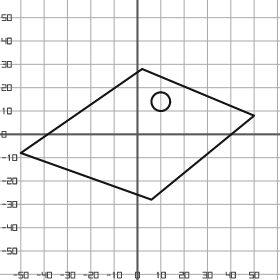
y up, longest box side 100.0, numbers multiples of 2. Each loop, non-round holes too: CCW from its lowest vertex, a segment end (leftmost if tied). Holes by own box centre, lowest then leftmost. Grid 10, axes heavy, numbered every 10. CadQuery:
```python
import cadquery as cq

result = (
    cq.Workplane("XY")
    .moveTo(6.0, -28.0)
    .lineTo(50.0, 8.0)
    .lineTo(2.0, 28.0)
    .lineTo(-50.0, -8.0)
    .close()
    .moveTo(10.0, 14.0)
    .circle(4.0)
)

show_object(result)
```